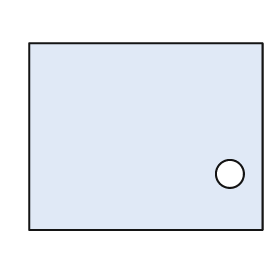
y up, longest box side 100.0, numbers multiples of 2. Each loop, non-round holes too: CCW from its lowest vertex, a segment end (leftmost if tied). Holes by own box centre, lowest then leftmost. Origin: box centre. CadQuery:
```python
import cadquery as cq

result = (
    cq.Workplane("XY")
    .moveTo(-50.0, -40.0)
    .lineTo(50.0, -40.0)
    .lineTo(50.0, 40.0)
    .lineTo(-50.0, 40.0)
    .close()
    .moveTo(36.0, -16.0)
    .circle(6.0)
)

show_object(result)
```